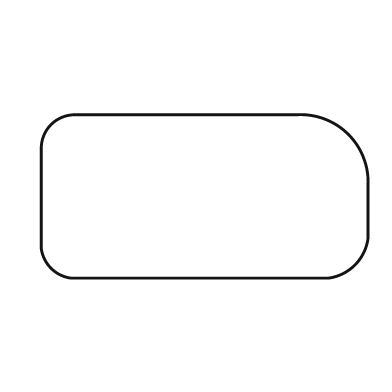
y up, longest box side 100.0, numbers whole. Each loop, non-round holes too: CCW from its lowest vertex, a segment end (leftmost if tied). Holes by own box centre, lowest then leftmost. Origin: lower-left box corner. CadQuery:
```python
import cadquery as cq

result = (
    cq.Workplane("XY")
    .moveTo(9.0, 0.0)
    .lineTo(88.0, 0.0)
    .threePointArc((96.0, 4.0), (100.0, 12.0))
    .lineTo(100.0, 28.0)
    .threePointArc((94.0, 44.0), (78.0, 50.0))
    .lineTo(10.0, 50.0)
    .threePointArc((3.0, 47.0), (0.0, 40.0))
    .lineTo(0.0, 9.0)
    .threePointArc((3.0, 3.0), (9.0, 0.0))
    .close()
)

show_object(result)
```